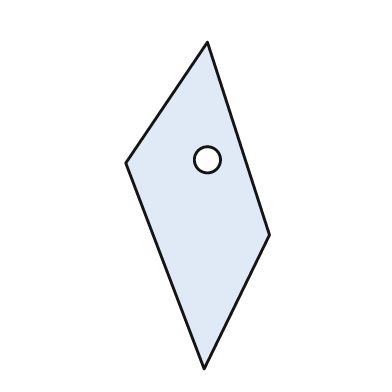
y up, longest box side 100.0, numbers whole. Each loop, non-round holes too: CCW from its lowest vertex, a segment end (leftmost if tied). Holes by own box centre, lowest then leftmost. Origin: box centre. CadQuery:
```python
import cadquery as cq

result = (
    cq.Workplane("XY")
    .moveTo(2.0, -50.0)
    .lineTo(22.0, -9.0)
    .lineTo(3.0, 50.0)
    .lineTo(-22.0, 13.0)
    .close()
    .moveTo(3.0, 14.0)
    .circle(4.0)
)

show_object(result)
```